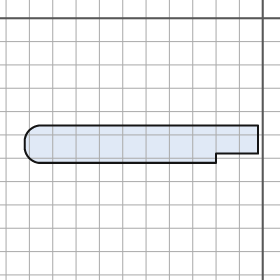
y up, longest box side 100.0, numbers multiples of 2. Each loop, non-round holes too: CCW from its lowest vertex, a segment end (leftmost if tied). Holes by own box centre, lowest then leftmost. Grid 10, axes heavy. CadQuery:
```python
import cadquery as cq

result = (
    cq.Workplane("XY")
    .moveTo(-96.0, -62.0)
    .lineTo(-20.0, -62.0)
    .lineTo(-20.0, -58.0)
    .lineTo(-2.0, -58.0)
    .lineTo(-2.0, -46.0)
    .lineTo(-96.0, -46.0)
    .threePointArc((-100.0, -48.0), (-102.0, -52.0))
    .lineTo(-102.0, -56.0)
    .threePointArc((-100.0, -60.0), (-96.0, -62.0))
    .close()
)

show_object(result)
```